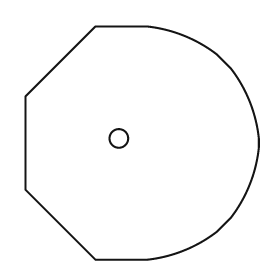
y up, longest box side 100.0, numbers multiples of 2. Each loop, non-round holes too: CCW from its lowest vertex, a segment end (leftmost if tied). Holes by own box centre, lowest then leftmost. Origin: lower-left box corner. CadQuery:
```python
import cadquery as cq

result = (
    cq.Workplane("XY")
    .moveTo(30.0, 0.0)
    .lineTo(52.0, 0.0)
    .threePointArc((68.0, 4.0), (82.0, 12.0))
    .lineTo(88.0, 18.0)
    .threePointArc((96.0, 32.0), (100.0, 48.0))
    .lineTo(100.0, 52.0)
    .threePointArc((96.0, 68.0), (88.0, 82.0))
    .lineTo(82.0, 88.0)
    .threePointArc((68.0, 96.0), (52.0, 100.0))
    .lineTo(30.0, 100.0)
    .lineTo(0.0, 70.0)
    .lineTo(0.0, 30.0)
    .close()
    .moveTo(40.0, 52.0)
    .circle(4.0)
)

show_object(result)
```